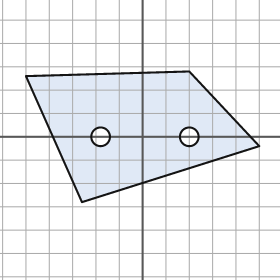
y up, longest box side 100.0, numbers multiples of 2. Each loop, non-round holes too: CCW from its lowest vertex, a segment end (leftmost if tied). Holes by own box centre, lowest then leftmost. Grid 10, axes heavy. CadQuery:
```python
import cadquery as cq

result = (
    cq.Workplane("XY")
    .moveTo(-26.0, -28.0)
    .lineTo(50.0, -4.0)
    .lineTo(20.0, 28.0)
    .lineTo(-50.0, 26.0)
    .close()
    .moveTo(-18.0, 0.0)
    .circle(4.0)
    .moveTo(20.0, 0.0)
    .circle(4.0)
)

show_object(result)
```